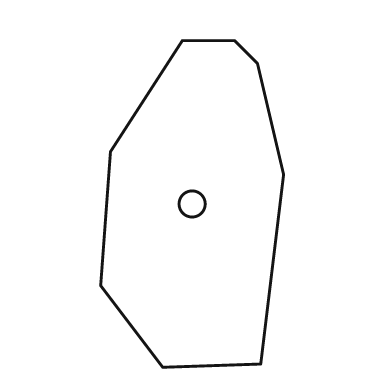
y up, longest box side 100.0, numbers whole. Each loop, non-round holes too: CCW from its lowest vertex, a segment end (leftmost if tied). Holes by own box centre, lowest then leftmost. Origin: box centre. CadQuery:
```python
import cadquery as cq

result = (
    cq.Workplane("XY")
    .moveTo(-9.0, -50.0)
    .lineTo(21.0, -49.0)
    .lineTo(28.0, 9.0)
    .lineTo(20.0, 43.0)
    .lineTo(13.0, 50.0)
    .lineTo(-3.0, 50.0)
    .lineTo(-25.0, 16.0)
    .lineTo(-28.0, -25.0)
    .close()
    .moveTo(0.0, 0.0)
    .circle(4.0)
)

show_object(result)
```